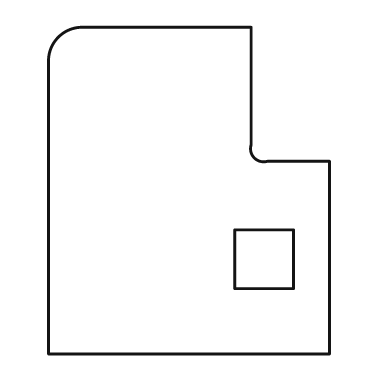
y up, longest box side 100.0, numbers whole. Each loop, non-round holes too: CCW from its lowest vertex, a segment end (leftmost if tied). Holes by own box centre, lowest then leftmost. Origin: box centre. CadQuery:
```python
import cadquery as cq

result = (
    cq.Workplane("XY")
    .moveTo(-43.0, -50.0)
    .lineTo(43.0, -50.0)
    .lineTo(43.0, 9.0)
    .lineTo(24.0, 9.0)
    .threePointArc((20.0, 10.0), (19.0, 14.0))
    .lineTo(19.0, 50.0)
    .lineTo(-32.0, 50.0)
    .threePointArc((-40.0, 47.0), (-43.0, 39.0))
    .close()
    .moveTo(14.0, -30.0)
    .lineTo(32.0, -30.0)
    .lineTo(32.0, -12.0)
    .lineTo(14.0, -12.0)
    .close()
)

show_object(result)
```